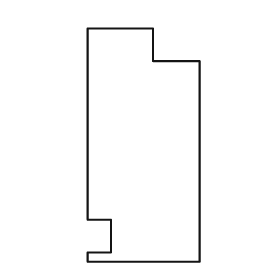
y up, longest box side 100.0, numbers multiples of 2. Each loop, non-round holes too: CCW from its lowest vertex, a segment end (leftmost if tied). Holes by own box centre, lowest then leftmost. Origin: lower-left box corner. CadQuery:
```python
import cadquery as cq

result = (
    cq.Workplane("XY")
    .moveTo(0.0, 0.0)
    .lineTo(48.0, 0.0)
    .lineTo(48.0, 86.0)
    .lineTo(28.0, 86.0)
    .lineTo(28.0, 100.0)
    .lineTo(0.0, 100.0)
    .lineTo(0.0, 18.0)
    .lineTo(10.0, 18.0)
    .lineTo(10.0, 4.0)
    .lineTo(0.0, 4.0)
    .close()
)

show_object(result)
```